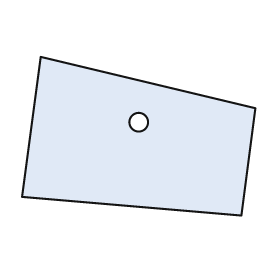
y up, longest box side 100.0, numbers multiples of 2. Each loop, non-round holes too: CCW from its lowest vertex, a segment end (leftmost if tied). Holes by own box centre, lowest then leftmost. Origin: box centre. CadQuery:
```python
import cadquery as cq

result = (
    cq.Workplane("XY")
    .moveTo(44.0, -34.0)
    .lineTo(50.0, 12.0)
    .lineTo(-42.0, 34.0)
    .lineTo(-50.0, -26.0)
    .close()
    .moveTo(0.0, 6.0)
    .circle(4.0)
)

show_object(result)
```